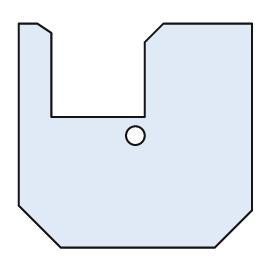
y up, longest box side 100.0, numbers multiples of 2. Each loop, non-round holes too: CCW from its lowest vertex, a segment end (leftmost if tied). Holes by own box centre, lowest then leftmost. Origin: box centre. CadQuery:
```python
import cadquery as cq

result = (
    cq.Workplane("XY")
    .moveTo(-32.0, -48.0)
    .lineTo(34.0, -48.0)
    .lineTo(50.0, -32.0)
    .lineTo(50.0, 48.0)
    .lineTo(12.0, 48.0)
    .lineTo(4.0, 40.0)
    .lineTo(4.0, 8.0)
    .lineTo(-36.0, 8.0)
    .lineTo(-36.0, 44.0)
    .lineTo(-42.0, 48.0)
    .lineTo(-50.0, 48.0)
    .lineTo(-50.0, -30.0)
    .close()
    .moveTo(0.0, 0.0)
    .circle(4.0)
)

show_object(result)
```